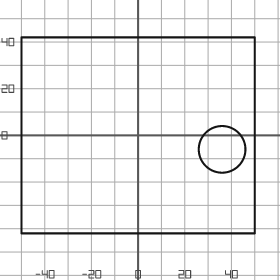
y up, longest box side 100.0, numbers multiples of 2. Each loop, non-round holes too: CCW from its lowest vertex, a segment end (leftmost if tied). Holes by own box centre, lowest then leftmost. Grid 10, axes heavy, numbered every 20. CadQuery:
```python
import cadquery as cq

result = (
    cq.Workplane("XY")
    .moveTo(-50.0, -42.0)
    .lineTo(50.0, -42.0)
    .lineTo(50.0, 42.0)
    .lineTo(-50.0, 42.0)
    .close()
    .moveTo(36.0, -6.0)
    .circle(10.0)
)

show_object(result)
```